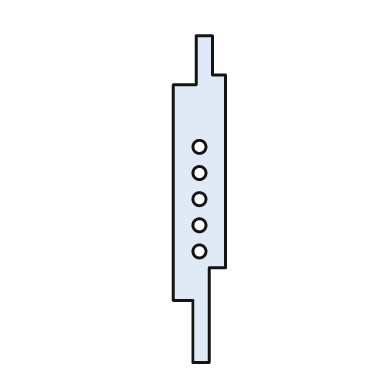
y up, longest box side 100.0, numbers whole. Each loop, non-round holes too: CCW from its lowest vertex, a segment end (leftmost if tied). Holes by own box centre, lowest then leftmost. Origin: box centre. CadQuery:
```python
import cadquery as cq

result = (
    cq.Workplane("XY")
    .moveTo(-2.0, -50.0)
    .lineTo(3.0, -50.0)
    .lineTo(3.0, -21.0)
    .lineTo(8.0, -21.0)
    .lineTo(8.0, 38.0)
    .lineTo(4.0, 38.0)
    .lineTo(4.0, 50.0)
    .lineTo(-1.0, 50.0)
    .lineTo(-1.0, 35.0)
    .lineTo(-8.0, 35.0)
    .lineTo(-8.0, -31.0)
    .lineTo(-2.0, -31.0)
    .close()
    .moveTo(0.0, -16.0)
    .circle(2.0)
    .moveTo(0.0, -8.0)
    .circle(2.0)
    .moveTo(0.0, 0.0)
    .circle(2.0)
    .moveTo(0.0, 8.0)
    .circle(2.0)
    .moveTo(0.0, 16.0)
    .circle(2.0)
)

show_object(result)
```